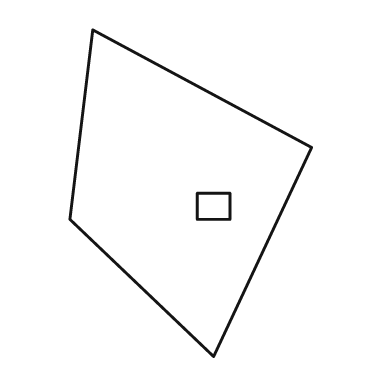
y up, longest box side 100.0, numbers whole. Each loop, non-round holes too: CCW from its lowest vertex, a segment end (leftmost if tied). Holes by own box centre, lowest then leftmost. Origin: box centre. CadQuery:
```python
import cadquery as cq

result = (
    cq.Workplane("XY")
    .moveTo(7.0, -50.0)
    .lineTo(37.0, 14.0)
    .lineTo(-30.0, 50.0)
    .lineTo(-37.0, -8.0)
    .close()
    .moveTo(2.0, -8.0)
    .lineTo(12.0, -8.0)
    .lineTo(12.0, 0.0)
    .lineTo(2.0, 0.0)
    .close()
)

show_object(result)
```